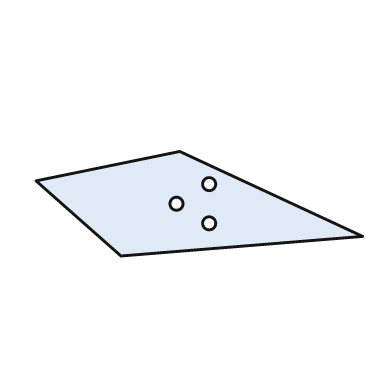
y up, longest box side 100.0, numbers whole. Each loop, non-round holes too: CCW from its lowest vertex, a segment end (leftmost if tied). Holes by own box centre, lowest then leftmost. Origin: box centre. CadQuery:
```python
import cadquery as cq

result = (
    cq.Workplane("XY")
    .moveTo(-24.0, -16.0)
    .lineTo(50.0, -10.0)
    .lineTo(-6.0, 16.0)
    .lineTo(-50.0, 7.0)
    .close()
    .moveTo(3.0, -6.0)
    .circle(2.0)
    .moveTo(-7.0, 0.0)
    .circle(2.0)
    .moveTo(3.0, 6.0)
    .circle(2.0)
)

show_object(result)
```